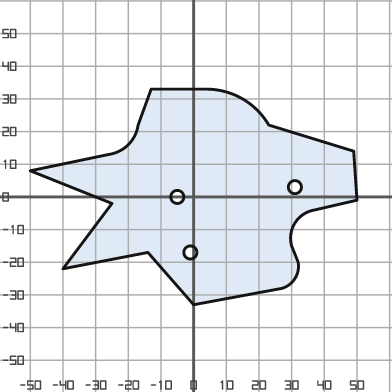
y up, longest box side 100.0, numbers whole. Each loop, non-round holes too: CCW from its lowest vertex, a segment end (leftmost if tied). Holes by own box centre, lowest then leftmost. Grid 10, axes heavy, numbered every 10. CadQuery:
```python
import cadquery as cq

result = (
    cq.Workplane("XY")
    .moveTo(0.0, -33.0)
    .lineTo(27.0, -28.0)
    .threePointArc((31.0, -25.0), (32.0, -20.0))
    .lineTo(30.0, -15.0)
    .threePointArc((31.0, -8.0), (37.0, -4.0))
    .lineTo(50.0, -1.0)
    .lineTo(49.0, 14.0)
    .lineTo(23.0, 22.0)
    .threePointArc((15.0, 30.0), (4.0, 33.0))
    .lineTo(-13.0, 33.0)
    .lineTo(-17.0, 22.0)
    .threePointArc((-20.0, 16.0), (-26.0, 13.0))
    .lineTo(-50.0, 8.0)
    .lineTo(-25.0, -2.0)
    .lineTo(-40.0, -22.0)
    .lineTo(-14.0, -17.0)
    .close()
    .moveTo(-1.0, -17.0)
    .circle(2.0)
    .moveTo(-5.0, 0.0)
    .circle(2.0)
    .moveTo(31.0, 3.0)
    .circle(2.0)
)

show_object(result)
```